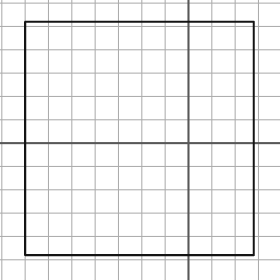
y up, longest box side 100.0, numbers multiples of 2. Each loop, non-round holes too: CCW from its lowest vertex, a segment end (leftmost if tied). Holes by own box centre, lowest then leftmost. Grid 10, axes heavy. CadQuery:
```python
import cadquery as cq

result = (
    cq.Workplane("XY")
    .moveTo(-70.0, -48.0)
    .lineTo(28.0, -48.0)
    .lineTo(28.0, 52.0)
    .lineTo(-70.0, 52.0)
    .close()
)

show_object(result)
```